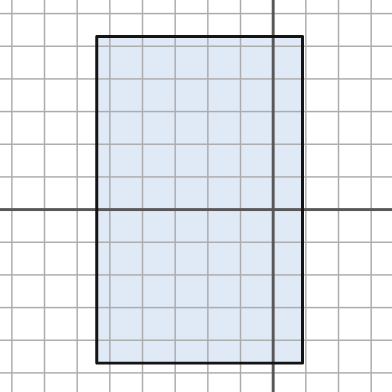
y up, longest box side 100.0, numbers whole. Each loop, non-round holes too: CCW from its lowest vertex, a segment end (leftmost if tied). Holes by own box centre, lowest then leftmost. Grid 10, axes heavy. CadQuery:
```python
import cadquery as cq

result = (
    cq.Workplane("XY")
    .moveTo(-54.0, -47.0)
    .lineTo(9.0, -47.0)
    .lineTo(9.0, 53.0)
    .lineTo(-54.0, 53.0)
    .close()
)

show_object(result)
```